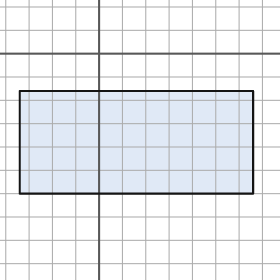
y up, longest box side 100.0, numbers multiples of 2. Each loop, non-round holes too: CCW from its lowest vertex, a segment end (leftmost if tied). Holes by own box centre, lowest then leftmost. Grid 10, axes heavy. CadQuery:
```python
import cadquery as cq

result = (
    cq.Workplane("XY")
    .moveTo(-34.0, -60.0)
    .lineTo(66.0, -60.0)
    .lineTo(66.0, -16.0)
    .lineTo(-34.0, -16.0)
    .close()
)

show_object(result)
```